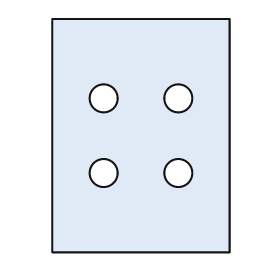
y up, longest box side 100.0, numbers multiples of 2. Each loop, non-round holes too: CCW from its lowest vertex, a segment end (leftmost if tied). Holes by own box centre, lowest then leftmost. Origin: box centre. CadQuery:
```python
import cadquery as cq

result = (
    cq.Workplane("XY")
    .moveTo(-38.0, -50.0)
    .lineTo(38.0, -50.0)
    .lineTo(38.0, 50.0)
    .lineTo(-38.0, 50.0)
    .close()
    .moveTo(-16.0, -16.0)
    .circle(6.0)
    .moveTo(16.0, -16.0)
    .circle(6.0)
    .moveTo(-16.0, 16.0)
    .circle(6.0)
    .moveTo(16.0, 16.0)
    .circle(6.0)
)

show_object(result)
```